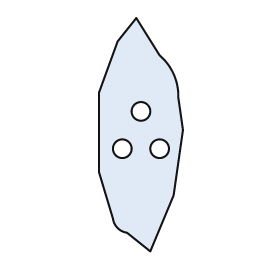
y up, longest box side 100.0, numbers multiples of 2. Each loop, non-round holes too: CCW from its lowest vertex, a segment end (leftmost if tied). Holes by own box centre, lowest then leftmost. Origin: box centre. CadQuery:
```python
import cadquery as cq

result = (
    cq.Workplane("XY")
    .moveTo(4.0, -50.0)
    .lineTo(14.0, -26.0)
    .lineTo(18.0, 2.0)
    .lineTo(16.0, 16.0)
    .threePointArc((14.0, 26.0), (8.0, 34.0))
    .lineTo(-2.0, 50.0)
    .lineTo(-10.0, 40.0)
    .lineTo(-18.0, 18.0)
    .lineTo(-18.0, -16.0)
    .lineTo(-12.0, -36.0)
    .threePointArc((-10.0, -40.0), (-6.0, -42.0))
    .close()
    .moveTo(-8.0, -6.0)
    .circle(4.0)
    .moveTo(8.0, -6.0)
    .circle(4.0)
    .moveTo(0.0, 10.0)
    .circle(4.0)
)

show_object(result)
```